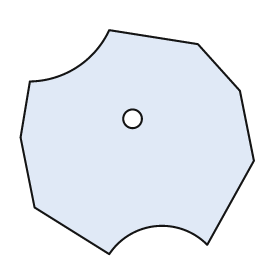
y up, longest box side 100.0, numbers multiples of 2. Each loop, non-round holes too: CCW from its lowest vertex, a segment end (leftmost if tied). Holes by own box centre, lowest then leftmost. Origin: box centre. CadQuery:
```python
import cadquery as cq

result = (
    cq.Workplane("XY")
    .moveTo(-12.0, -48.0)
    .threePointArc((8.0, -36.0), (30.0, -44.0))
    .lineTo(50.0, -8.0)
    .lineTo(44.0, 22.0)
    .lineTo(26.0, 42.0)
    .lineTo(-12.0, 48.0)
    .threePointArc((-26.0, 32.0), (-46.0, 26.0))
    .lineTo(-50.0, 2.0)
    .lineTo(-44.0, -28.0)
    .close()
    .moveTo(-2.0, 10.0)
    .circle(4.0)
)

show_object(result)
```